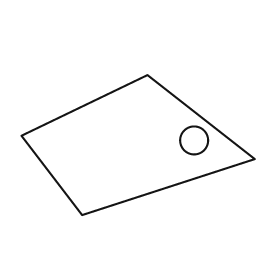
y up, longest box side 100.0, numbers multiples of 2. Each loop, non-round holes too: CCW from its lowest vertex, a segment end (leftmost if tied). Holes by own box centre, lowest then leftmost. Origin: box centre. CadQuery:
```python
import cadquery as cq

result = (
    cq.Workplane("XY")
    .moveTo(-24.0, -30.0)
    .lineTo(50.0, -6.0)
    .lineTo(4.0, 30.0)
    .lineTo(-50.0, 4.0)
    .close()
    .moveTo(24.0, 2.0)
    .circle(6.0)
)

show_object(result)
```